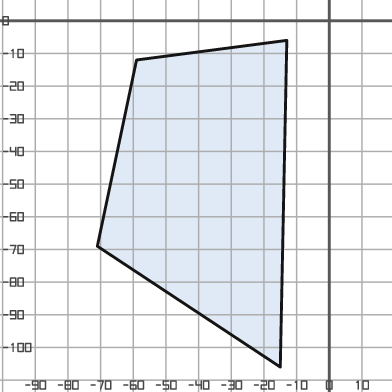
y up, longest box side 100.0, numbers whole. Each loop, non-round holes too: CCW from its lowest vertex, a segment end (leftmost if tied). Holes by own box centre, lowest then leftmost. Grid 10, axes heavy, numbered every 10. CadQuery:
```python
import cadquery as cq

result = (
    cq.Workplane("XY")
    .moveTo(-15.0, -106.0)
    .lineTo(-13.0, -6.0)
    .lineTo(-59.0, -12.0)
    .lineTo(-71.0, -69.0)
    .close()
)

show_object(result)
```